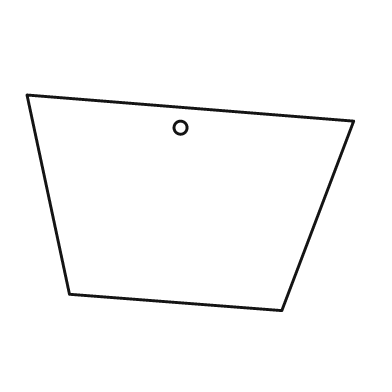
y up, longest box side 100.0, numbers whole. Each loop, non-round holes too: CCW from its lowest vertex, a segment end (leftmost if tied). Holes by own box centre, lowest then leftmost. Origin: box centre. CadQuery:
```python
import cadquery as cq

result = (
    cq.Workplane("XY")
    .moveTo(28.0, -33.0)
    .lineTo(50.0, 25.0)
    .lineTo(-50.0, 33.0)
    .lineTo(-37.0, -28.0)
    .close()
    .moveTo(-3.0, 23.0)
    .circle(2.0)
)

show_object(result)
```